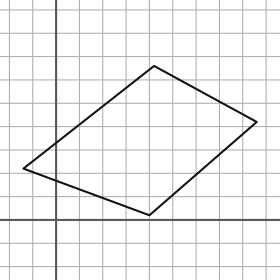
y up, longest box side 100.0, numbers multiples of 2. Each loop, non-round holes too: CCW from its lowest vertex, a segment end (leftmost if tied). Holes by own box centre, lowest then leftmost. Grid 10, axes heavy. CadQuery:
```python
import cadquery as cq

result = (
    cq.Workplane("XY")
    .moveTo(40.0, 2.0)
    .lineTo(86.0, 42.0)
    .lineTo(42.0, 66.0)
    .lineTo(-14.0, 22.0)
    .close()
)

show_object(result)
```